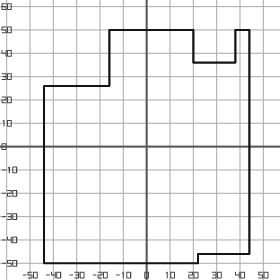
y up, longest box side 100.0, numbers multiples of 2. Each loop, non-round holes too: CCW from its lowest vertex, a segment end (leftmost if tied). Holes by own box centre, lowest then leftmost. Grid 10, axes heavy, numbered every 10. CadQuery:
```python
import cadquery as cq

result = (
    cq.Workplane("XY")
    .moveTo(-44.0, -50.0)
    .lineTo(22.0, -50.0)
    .lineTo(22.0, -46.0)
    .lineTo(44.0, -46.0)
    .lineTo(44.0, 50.0)
    .lineTo(38.0, 50.0)
    .lineTo(38.0, 36.0)
    .lineTo(20.0, 36.0)
    .lineTo(20.0, 50.0)
    .lineTo(-16.0, 50.0)
    .lineTo(-16.0, 26.0)
    .lineTo(-44.0, 26.0)
    .close()
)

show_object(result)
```